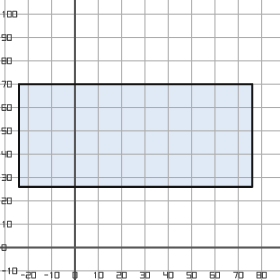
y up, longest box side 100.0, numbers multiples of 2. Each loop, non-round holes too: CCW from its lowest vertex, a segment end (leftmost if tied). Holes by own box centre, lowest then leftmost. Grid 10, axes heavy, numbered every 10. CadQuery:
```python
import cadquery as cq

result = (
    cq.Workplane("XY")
    .moveTo(-24.0, 26.0)
    .lineTo(76.0, 26.0)
    .lineTo(76.0, 70.0)
    .lineTo(-24.0, 70.0)
    .close()
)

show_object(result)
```